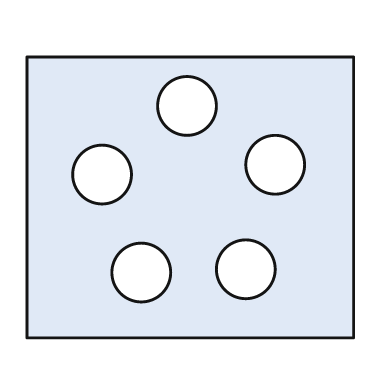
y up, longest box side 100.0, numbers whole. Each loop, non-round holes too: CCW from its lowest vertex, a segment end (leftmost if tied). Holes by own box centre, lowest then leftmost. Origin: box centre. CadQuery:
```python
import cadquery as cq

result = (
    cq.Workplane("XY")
    .moveTo(-50.0, -43.0)
    .lineTo(50.0, -43.0)
    .lineTo(50.0, 43.0)
    .lineTo(-50.0, 43.0)
    .close()
    .moveTo(-15.0, -23.0)
    .circle(9.0)
    .moveTo(17.0, -22.0)
    .circle(9.0)
    .moveTo(-27.0, 7.0)
    .circle(9.0)
    .moveTo(26.0, 10.0)
    .circle(9.0)
    .moveTo(-1.0, 28.0)
    .circle(9.0)
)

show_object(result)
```